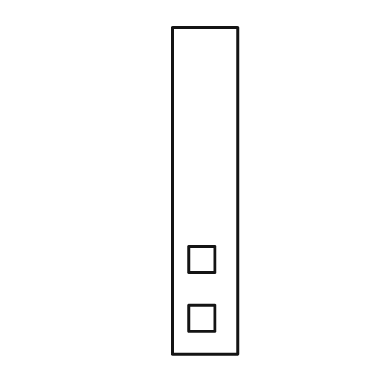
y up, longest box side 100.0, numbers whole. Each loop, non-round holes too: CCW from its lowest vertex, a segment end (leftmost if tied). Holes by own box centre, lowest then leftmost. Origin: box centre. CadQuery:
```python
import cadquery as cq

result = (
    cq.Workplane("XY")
    .moveTo(-10.0, -50.0)
    .lineTo(10.0, -50.0)
    .lineTo(10.0, 50.0)
    .lineTo(-10.0, 50.0)
    .close()
    .moveTo(-5.0, -43.0)
    .lineTo(3.0, -43.0)
    .lineTo(3.0, -35.0)
    .lineTo(-5.0, -35.0)
    .close()
    .moveTo(-5.0, -25.0)
    .lineTo(3.0, -25.0)
    .lineTo(3.0, -17.0)
    .lineTo(-5.0, -17.0)
    .close()
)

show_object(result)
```